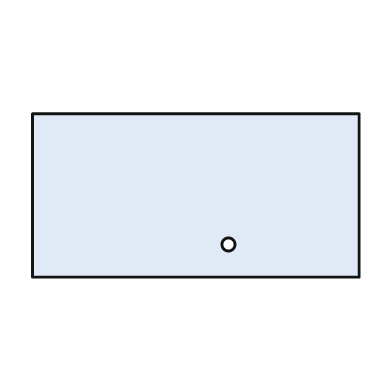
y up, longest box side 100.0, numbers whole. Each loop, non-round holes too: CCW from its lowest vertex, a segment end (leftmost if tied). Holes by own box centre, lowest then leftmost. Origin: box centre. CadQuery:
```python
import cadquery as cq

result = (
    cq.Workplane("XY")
    .moveTo(-50.0, -25.0)
    .lineTo(50.0, -25.0)
    .lineTo(50.0, 25.0)
    .lineTo(-50.0, 25.0)
    .close()
    .moveTo(10.0, -15.0)
    .circle(2.0)
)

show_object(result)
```